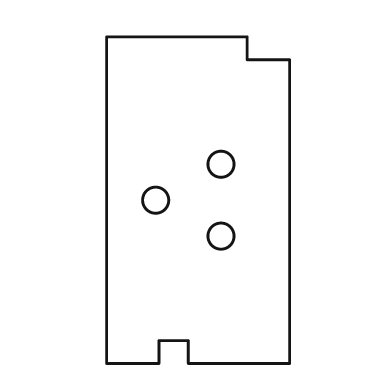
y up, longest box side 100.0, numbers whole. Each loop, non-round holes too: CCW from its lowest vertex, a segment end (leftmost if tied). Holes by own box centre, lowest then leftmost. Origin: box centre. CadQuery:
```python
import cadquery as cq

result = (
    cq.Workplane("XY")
    .moveTo(-28.0, -50.0)
    .lineTo(-12.0, -50.0)
    .lineTo(-12.0, -43.0)
    .lineTo(-3.0, -43.0)
    .lineTo(-3.0, -50.0)
    .lineTo(28.0, -50.0)
    .lineTo(28.0, 43.0)
    .lineTo(15.0, 43.0)
    .lineTo(15.0, 50.0)
    .lineTo(-28.0, 50.0)
    .close()
    .moveTo(7.0, -11.0)
    .circle(4.0)
    .moveTo(-13.0, 0.0)
    .circle(4.0)
    .moveTo(7.0, 11.0)
    .circle(4.0)
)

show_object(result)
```